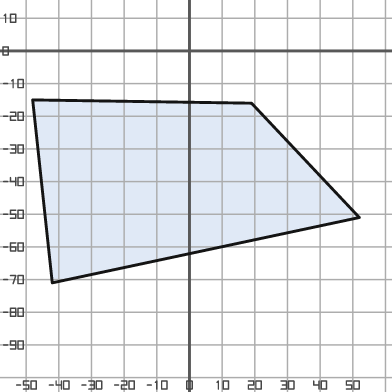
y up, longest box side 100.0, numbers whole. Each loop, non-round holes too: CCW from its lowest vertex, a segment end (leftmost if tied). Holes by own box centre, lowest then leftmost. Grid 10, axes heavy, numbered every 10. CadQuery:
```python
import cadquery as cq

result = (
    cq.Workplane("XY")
    .moveTo(-42.0, -71.0)
    .lineTo(52.0, -51.0)
    .lineTo(19.0, -16.0)
    .lineTo(-48.0, -15.0)
    .close()
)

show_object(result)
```